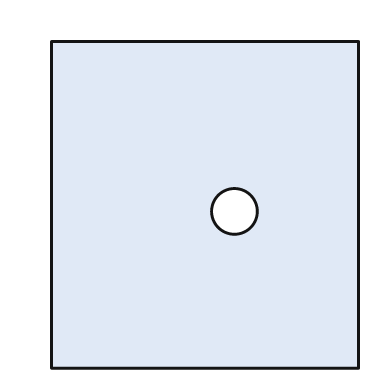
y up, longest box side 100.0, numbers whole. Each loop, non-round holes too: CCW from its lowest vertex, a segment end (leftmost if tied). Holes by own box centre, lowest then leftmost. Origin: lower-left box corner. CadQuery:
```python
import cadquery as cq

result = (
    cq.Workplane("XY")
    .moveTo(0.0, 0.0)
    .lineTo(94.0, 0.0)
    .lineTo(94.0, 100.0)
    .lineTo(0.0, 100.0)
    .close()
    .moveTo(56.0, 48.0)
    .circle(7.0)
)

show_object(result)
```